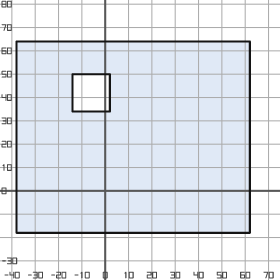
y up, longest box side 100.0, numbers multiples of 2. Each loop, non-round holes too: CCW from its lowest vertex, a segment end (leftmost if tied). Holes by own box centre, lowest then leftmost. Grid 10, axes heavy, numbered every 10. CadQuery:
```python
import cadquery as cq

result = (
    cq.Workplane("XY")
    .moveTo(-38.0, -18.0)
    .lineTo(62.0, -18.0)
    .lineTo(62.0, 64.0)
    .lineTo(-38.0, 64.0)
    .close()
    .moveTo(-14.0, 34.0)
    .lineTo(2.0, 34.0)
    .lineTo(2.0, 50.0)
    .lineTo(-14.0, 50.0)
    .close()
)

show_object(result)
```